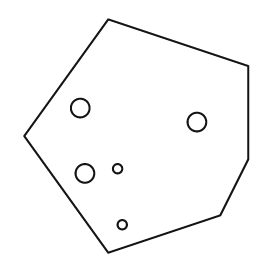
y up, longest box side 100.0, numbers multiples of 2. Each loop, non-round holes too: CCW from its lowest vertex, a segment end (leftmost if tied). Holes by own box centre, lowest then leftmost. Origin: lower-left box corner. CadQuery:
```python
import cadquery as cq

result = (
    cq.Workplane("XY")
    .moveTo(36.0, 0.0)
    .lineTo(84.0, 16.0)
    .lineTo(96.0, 40.0)
    .lineTo(96.0, 80.0)
    .lineTo(36.0, 100.0)
    .lineTo(0.0, 50.0)
    .close()
    .moveTo(42.0, 12.0)
    .circle(2.0)
    .moveTo(26.0, 34.0)
    .circle(4.0)
    .moveTo(40.0, 36.0)
    .circle(2.0)
    .moveTo(74.0, 56.0)
    .circle(4.0)
    .moveTo(24.0, 62.0)
    .circle(4.0)
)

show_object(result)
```